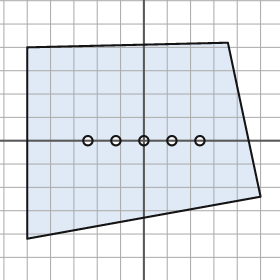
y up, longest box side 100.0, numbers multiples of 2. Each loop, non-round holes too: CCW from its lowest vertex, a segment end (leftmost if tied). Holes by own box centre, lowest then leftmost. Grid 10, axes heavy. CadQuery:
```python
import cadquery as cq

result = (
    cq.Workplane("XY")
    .moveTo(-50.0, -42.0)
    .lineTo(50.0, -24.0)
    .lineTo(36.0, 42.0)
    .lineTo(-50.0, 40.0)
    .close()
    .moveTo(-24.0, 0.0)
    .circle(2.0)
    .moveTo(-12.0, 0.0)
    .circle(2.0)
    .moveTo(0.0, 0.0)
    .circle(2.0)
    .moveTo(12.0, 0.0)
    .circle(2.0)
    .moveTo(24.0, 0.0)
    .circle(2.0)
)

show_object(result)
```